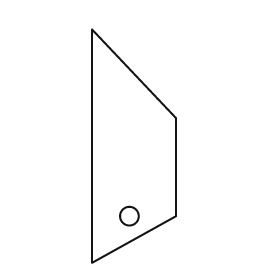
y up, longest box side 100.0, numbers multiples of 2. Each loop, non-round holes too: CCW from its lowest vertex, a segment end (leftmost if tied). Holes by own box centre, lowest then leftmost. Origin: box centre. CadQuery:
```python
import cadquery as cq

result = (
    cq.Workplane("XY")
    .moveTo(-18.0, -50.0)
    .lineTo(18.0, -30.0)
    .lineTo(18.0, 12.0)
    .lineTo(-18.0, 50.0)
    .close()
    .moveTo(-2.0, -30.0)
    .circle(4.0)
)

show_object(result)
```